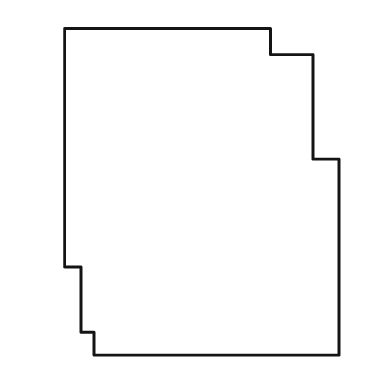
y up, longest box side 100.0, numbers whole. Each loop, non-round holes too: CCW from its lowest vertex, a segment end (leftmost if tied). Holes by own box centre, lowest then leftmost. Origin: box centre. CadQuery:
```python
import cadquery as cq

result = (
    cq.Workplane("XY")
    .moveTo(-33.0, -50.0)
    .lineTo(42.0, -50.0)
    .lineTo(42.0, 10.0)
    .lineTo(34.0, 10.0)
    .lineTo(34.0, 42.0)
    .lineTo(21.0, 42.0)
    .lineTo(21.0, 50.0)
    .lineTo(-42.0, 50.0)
    .lineTo(-42.0, -23.0)
    .lineTo(-37.0, -23.0)
    .lineTo(-37.0, -43.0)
    .lineTo(-33.0, -43.0)
    .close()
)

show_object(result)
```